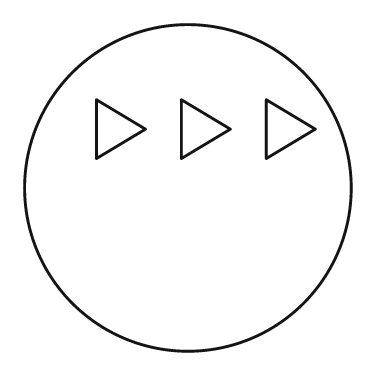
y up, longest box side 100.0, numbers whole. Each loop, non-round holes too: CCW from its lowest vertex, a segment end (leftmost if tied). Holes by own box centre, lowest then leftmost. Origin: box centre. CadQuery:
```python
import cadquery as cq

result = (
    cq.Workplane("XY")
    .moveTo(0.0, 0.0)
    .circle(50.0)
    .moveTo(-28.0, 9.0)
    .lineTo(-13.0, 18.0)
    .lineTo(-28.0, 27.0)
    .close()
    .moveTo(-2.0, 9.0)
    .lineTo(13.0, 18.0)
    .lineTo(-2.0, 27.0)
    .close()
    .moveTo(24.0, 9.0)
    .lineTo(39.0, 18.0)
    .lineTo(24.0, 27.0)
    .close()
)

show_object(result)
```